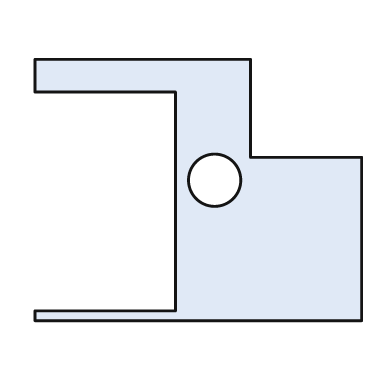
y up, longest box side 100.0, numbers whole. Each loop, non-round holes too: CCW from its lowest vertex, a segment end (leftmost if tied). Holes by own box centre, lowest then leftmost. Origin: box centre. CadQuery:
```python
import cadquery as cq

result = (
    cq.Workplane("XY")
    .moveTo(-50.0, -40.0)
    .lineTo(50.0, -40.0)
    .lineTo(50.0, 10.0)
    .lineTo(16.0, 10.0)
    .lineTo(16.0, 40.0)
    .lineTo(-50.0, 40.0)
    .lineTo(-50.0, 30.0)
    .lineTo(-7.0, 30.0)
    .lineTo(-7.0, -37.0)
    .lineTo(-50.0, -37.0)
    .close()
    .moveTo(5.0, 3.0)
    .circle(8.0)
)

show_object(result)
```